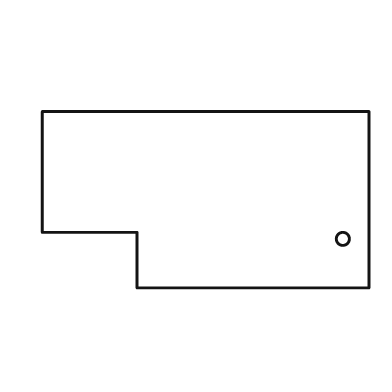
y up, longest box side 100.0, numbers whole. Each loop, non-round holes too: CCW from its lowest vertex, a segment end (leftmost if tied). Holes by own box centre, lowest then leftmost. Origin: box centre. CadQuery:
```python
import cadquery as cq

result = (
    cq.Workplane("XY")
    .moveTo(-21.0, -27.0)
    .lineTo(50.0, -27.0)
    .lineTo(50.0, 27.0)
    .lineTo(-50.0, 27.0)
    .lineTo(-50.0, -10.0)
    .lineTo(-21.0, -10.0)
    .close()
    .moveTo(42.0, -12.0)
    .circle(2.0)
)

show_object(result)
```